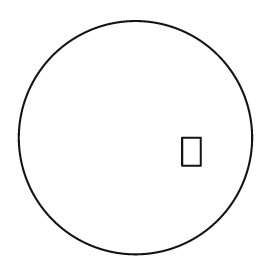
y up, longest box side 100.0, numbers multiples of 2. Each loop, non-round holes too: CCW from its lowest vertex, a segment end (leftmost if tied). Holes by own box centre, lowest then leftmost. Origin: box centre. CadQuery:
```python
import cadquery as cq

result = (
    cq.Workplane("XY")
    .moveTo(0.0, 0.0)
    .circle(50.0)
    .moveTo(20.0, -12.0)
    .lineTo(28.0, -12.0)
    .lineTo(28.0, 0.0)
    .lineTo(20.0, 0.0)
    .close()
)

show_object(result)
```